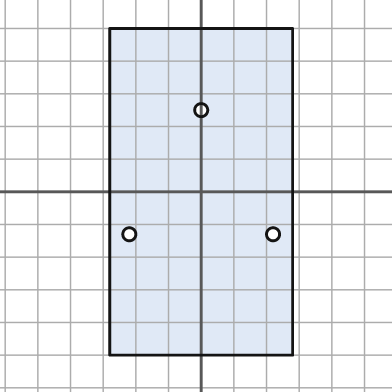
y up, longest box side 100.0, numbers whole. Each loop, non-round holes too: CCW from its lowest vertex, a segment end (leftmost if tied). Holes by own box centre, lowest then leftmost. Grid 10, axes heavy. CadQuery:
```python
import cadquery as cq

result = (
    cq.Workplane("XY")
    .moveTo(-28.0, -50.0)
    .lineTo(28.0, -50.0)
    .lineTo(28.0, 50.0)
    .lineTo(-28.0, 50.0)
    .close()
    .moveTo(-22.0, -13.0)
    .circle(2.0)
    .moveTo(22.0, -13.0)
    .circle(2.0)
    .moveTo(0.0, 25.0)
    .circle(2.0)
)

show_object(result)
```